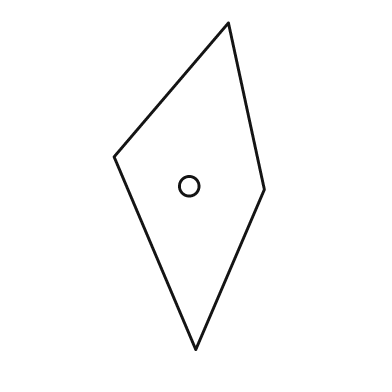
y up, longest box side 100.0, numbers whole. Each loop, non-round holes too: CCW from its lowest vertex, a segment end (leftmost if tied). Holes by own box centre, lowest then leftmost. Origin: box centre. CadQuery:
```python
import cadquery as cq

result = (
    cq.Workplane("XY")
    .moveTo(2.0, -50.0)
    .lineTo(23.0, -1.0)
    .lineTo(12.0, 50.0)
    .lineTo(-23.0, 9.0)
    .close()
    .moveTo(0.0, 0.0)
    .circle(3.0)
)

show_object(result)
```